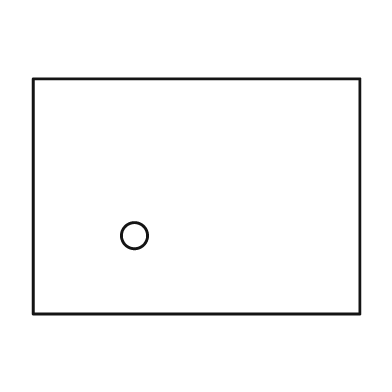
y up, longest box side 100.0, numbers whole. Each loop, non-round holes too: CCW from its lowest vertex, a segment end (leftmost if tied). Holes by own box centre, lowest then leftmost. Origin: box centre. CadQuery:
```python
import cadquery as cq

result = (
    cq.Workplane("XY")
    .moveTo(-50.0, -36.0)
    .lineTo(50.0, -36.0)
    .lineTo(50.0, 36.0)
    .lineTo(-50.0, 36.0)
    .close()
    .moveTo(-19.0, -12.0)
    .circle(4.0)
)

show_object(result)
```